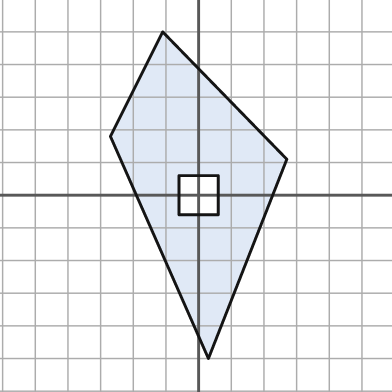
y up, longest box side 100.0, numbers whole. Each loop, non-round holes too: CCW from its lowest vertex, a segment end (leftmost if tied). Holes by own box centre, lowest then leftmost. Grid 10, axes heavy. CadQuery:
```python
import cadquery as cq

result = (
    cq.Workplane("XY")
    .moveTo(3.0, -50.0)
    .lineTo(27.0, 11.0)
    .lineTo(-11.0, 50.0)
    .lineTo(-27.0, 18.0)
    .close()
    .moveTo(-6.0, -6.0)
    .lineTo(6.0, -6.0)
    .lineTo(6.0, 6.0)
    .lineTo(-6.0, 6.0)
    .close()
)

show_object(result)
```